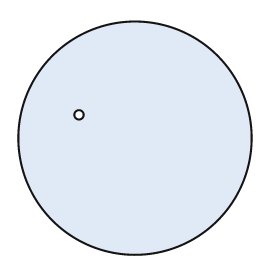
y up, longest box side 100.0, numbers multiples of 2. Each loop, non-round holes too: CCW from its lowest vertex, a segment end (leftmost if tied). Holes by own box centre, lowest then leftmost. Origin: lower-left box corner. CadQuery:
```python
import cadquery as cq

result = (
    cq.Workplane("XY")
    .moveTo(50.0, 50.0)
    .circle(50.0)
    .moveTo(26.0, 60.0)
    .circle(2.0)
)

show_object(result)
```